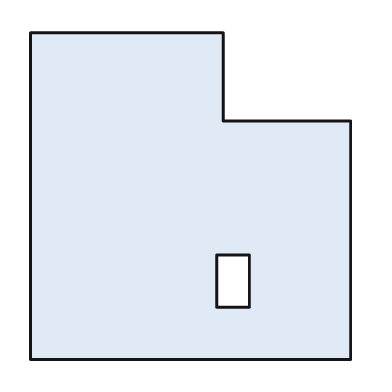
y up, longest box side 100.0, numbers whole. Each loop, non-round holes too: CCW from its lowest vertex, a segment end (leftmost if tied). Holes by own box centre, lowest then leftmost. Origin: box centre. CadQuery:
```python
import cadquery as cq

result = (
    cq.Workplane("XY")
    .moveTo(-49.0, -50.0)
    .lineTo(49.0, -50.0)
    .lineTo(49.0, 23.0)
    .lineTo(10.0, 23.0)
    .lineTo(10.0, 50.0)
    .lineTo(-49.0, 50.0)
    .close()
    .moveTo(8.0, -34.0)
    .lineTo(18.0, -34.0)
    .lineTo(18.0, -18.0)
    .lineTo(8.0, -18.0)
    .close()
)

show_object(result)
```